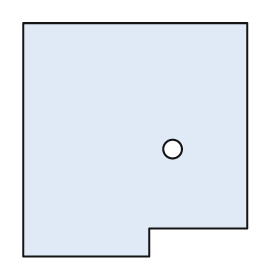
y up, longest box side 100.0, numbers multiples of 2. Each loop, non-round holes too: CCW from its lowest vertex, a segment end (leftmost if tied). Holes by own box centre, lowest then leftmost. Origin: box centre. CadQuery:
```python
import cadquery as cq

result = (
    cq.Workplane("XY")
    .moveTo(-48.0, -50.0)
    .lineTo(6.0, -50.0)
    .lineTo(6.0, -38.0)
    .lineTo(48.0, -38.0)
    .lineTo(48.0, 50.0)
    .lineTo(-48.0, 50.0)
    .close()
    .moveTo(16.0, -4.0)
    .circle(4.0)
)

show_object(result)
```